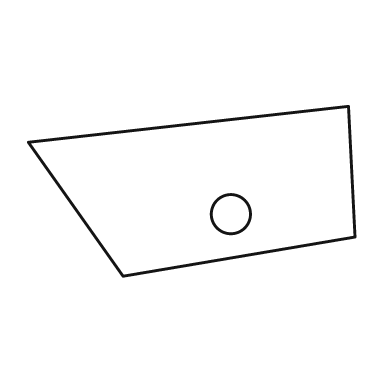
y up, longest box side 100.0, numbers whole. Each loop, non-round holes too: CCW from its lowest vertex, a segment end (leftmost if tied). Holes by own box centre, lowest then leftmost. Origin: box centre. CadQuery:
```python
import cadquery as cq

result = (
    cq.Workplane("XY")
    .moveTo(-21.0, -26.0)
    .lineTo(50.0, -14.0)
    .lineTo(48.0, 26.0)
    .lineTo(-50.0, 15.0)
    .close()
    .moveTo(12.0, -7.0)
    .circle(6.0)
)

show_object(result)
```